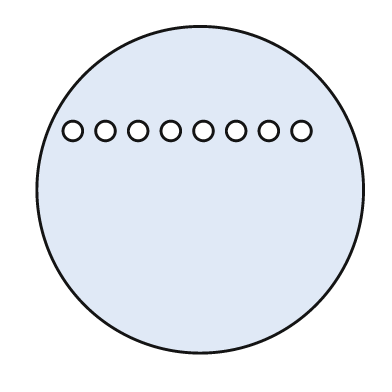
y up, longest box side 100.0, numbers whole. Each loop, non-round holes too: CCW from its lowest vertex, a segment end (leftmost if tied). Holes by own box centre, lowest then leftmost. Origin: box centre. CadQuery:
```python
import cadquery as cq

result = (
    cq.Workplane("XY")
    .moveTo(0.0, 0.0)
    .circle(50.0)
    .moveTo(-39.0, 18.0)
    .circle(3.0)
    .moveTo(-29.0, 18.0)
    .circle(3.0)
    .moveTo(-19.0, 18.0)
    .circle(3.0)
    .moveTo(-9.0, 18.0)
    .circle(3.0)
    .moveTo(1.0, 18.0)
    .circle(3.0)
    .moveTo(11.0, 18.0)
    .circle(3.0)
    .moveTo(21.0, 18.0)
    .circle(3.0)
    .moveTo(31.0, 18.0)
    .circle(3.0)
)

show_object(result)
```